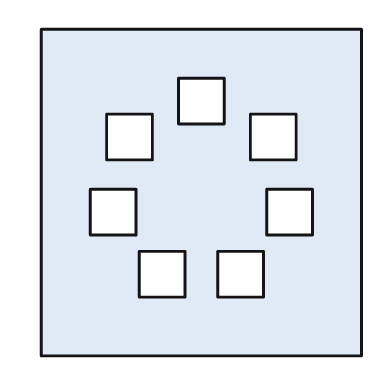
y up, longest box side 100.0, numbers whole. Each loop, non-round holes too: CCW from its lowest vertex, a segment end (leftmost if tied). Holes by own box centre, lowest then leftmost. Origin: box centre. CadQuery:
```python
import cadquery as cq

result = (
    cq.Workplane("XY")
    .moveTo(-49.0, -50.0)
    .lineTo(49.0, -50.0)
    .lineTo(49.0, 50.0)
    .lineTo(-49.0, 50.0)
    .close()
    .moveTo(-19.0, -32.0)
    .lineTo(-5.0, -32.0)
    .lineTo(-5.0, -18.0)
    .lineTo(-19.0, -18.0)
    .close()
    .moveTo(5.0, -32.0)
    .lineTo(19.0, -32.0)
    .lineTo(19.0, -18.0)
    .lineTo(5.0, -18.0)
    .close()
    .moveTo(-34.0, -13.0)
    .lineTo(-20.0, -13.0)
    .lineTo(-20.0, 1.0)
    .lineTo(-34.0, 1.0)
    .close()
    .moveTo(20.0, -13.0)
    .lineTo(34.0, -13.0)
    .lineTo(34.0, 1.0)
    .lineTo(20.0, 1.0)
    .close()
    .moveTo(-29.0, 10.0)
    .lineTo(-15.0, 10.0)
    .lineTo(-15.0, 24.0)
    .lineTo(-29.0, 24.0)
    .close()
    .moveTo(15.0, 10.0)
    .lineTo(29.0, 10.0)
    .lineTo(29.0, 24.0)
    .lineTo(15.0, 24.0)
    .close()
    .moveTo(-7.0, 21.0)
    .lineTo(7.0, 21.0)
    .lineTo(7.0, 35.0)
    .lineTo(-7.0, 35.0)
    .close()
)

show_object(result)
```